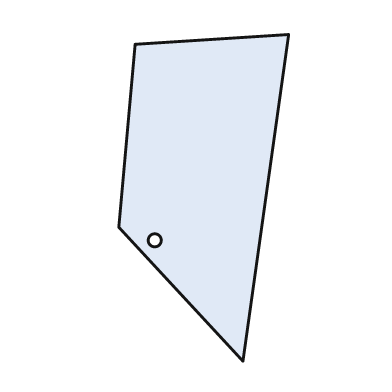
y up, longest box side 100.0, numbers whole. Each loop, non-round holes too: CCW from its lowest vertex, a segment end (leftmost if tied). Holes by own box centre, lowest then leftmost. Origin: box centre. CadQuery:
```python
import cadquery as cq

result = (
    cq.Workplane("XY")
    .moveTo(12.0, -50.0)
    .lineTo(26.0, 50.0)
    .lineTo(-21.0, 47.0)
    .lineTo(-26.0, -9.0)
    .close()
    .moveTo(-15.0, -13.0)
    .circle(2.0)
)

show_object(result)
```